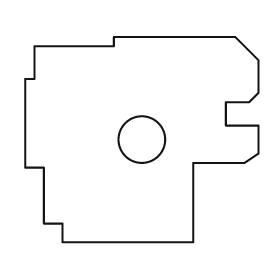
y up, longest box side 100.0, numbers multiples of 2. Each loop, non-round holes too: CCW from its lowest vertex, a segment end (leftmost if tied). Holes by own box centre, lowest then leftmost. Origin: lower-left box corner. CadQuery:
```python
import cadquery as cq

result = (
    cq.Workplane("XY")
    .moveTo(16.0, 0.0)
    .lineTo(72.0, 0.0)
    .lineTo(72.0, 34.0)
    .lineTo(94.0, 34.0)
    .lineTo(100.0, 38.0)
    .lineTo(100.0, 50.0)
    .lineTo(86.0, 50.0)
    .lineTo(86.0, 60.0)
    .lineTo(96.0, 60.0)
    .lineTo(100.0, 64.0)
    .lineTo(100.0, 78.0)
    .lineTo(90.0, 88.0)
    .lineTo(38.0, 88.0)
    .lineTo(38.0, 84.0)
    .lineTo(4.0, 84.0)
    .lineTo(4.0, 70.0)
    .lineTo(0.0, 70.0)
    .lineTo(0.0, 32.0)
    .lineTo(8.0, 32.0)
    .lineTo(8.0, 8.0)
    .lineTo(16.0, 8.0)
    .close()
    .moveTo(50.0, 44.0)
    .circle(10.0)
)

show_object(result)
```